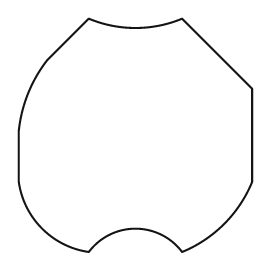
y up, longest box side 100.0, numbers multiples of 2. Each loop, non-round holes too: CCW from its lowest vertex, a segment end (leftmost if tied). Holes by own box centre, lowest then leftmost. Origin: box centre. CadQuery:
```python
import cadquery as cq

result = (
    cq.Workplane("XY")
    .moveTo(-20.0, -50.0)
    .threePointArc((0.0, -40.0), (20.0, -50.0))
    .threePointArc((38.0, -38.0), (50.0, -20.0))
    .lineTo(50.0, 20.0)
    .lineTo(20.0, 50.0)
    .threePointArc((0.0, 46.0), (-20.0, 50.0))
    .lineTo(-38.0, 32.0)
    .threePointArc((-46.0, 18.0), (-50.0, 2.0))
    .lineTo(-50.0, -20.0)
    .threePointArc((-40.0, -40.0), (-20.0, -50.0))
    .close()
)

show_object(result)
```